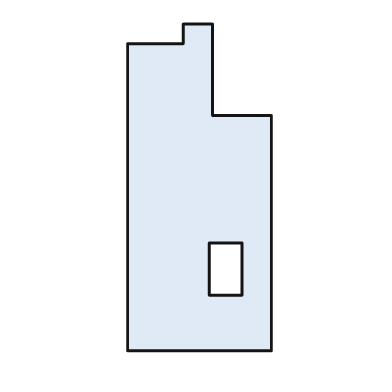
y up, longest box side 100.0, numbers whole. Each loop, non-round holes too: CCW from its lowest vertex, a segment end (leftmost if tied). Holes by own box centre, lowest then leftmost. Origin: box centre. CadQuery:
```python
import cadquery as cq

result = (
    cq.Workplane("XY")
    .moveTo(-22.0, -50.0)
    .lineTo(22.0, -50.0)
    .lineTo(22.0, 22.0)
    .lineTo(4.0, 22.0)
    .lineTo(4.0, 50.0)
    .lineTo(-5.0, 50.0)
    .lineTo(-5.0, 44.0)
    .lineTo(-22.0, 44.0)
    .close()
    .moveTo(3.0, -33.0)
    .lineTo(13.0, -33.0)
    .lineTo(13.0, -17.0)
    .lineTo(3.0, -17.0)
    .close()
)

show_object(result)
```